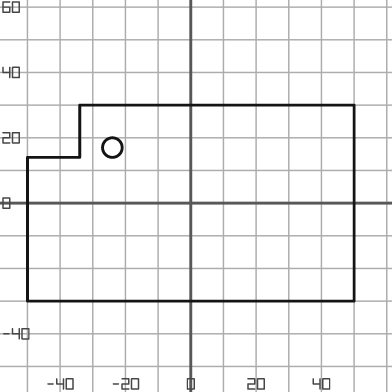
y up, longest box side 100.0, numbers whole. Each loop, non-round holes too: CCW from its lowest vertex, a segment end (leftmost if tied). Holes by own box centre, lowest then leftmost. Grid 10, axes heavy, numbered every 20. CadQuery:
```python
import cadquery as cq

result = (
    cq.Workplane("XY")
    .moveTo(-50.0, -30.0)
    .lineTo(50.0, -30.0)
    .lineTo(50.0, 30.0)
    .lineTo(-34.0, 30.0)
    .lineTo(-34.0, 14.0)
    .lineTo(-50.0, 14.0)
    .close()
    .moveTo(-24.0, 17.0)
    .circle(3.0)
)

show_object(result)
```